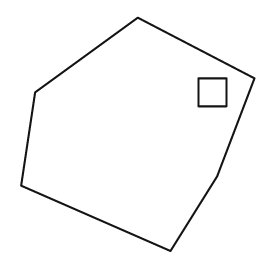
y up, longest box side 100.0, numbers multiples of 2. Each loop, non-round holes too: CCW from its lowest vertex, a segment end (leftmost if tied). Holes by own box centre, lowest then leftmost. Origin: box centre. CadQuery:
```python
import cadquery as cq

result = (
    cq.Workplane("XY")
    .moveTo(14.0, -50.0)
    .lineTo(34.0, -18.0)
    .lineTo(50.0, 24.0)
    .lineTo(0.0, 50.0)
    .lineTo(-44.0, 18.0)
    .lineTo(-50.0, -22.0)
    .close()
    .moveTo(26.0, 12.0)
    .lineTo(38.0, 12.0)
    .lineTo(38.0, 24.0)
    .lineTo(26.0, 24.0)
    .close()
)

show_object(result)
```